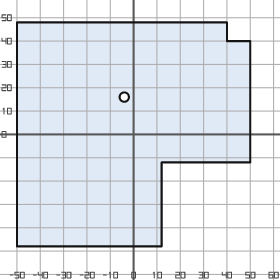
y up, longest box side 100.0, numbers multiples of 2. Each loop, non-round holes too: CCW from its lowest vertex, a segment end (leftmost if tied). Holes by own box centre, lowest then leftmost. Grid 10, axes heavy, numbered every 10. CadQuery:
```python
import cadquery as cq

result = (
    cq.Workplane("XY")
    .moveTo(-50.0, -48.0)
    .lineTo(12.0, -48.0)
    .lineTo(12.0, -12.0)
    .lineTo(50.0, -12.0)
    .lineTo(50.0, 40.0)
    .lineTo(40.0, 40.0)
    .lineTo(40.0, 48.0)
    .lineTo(-50.0, 48.0)
    .close()
    .moveTo(-4.0, 16.0)
    .circle(2.0)
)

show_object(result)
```